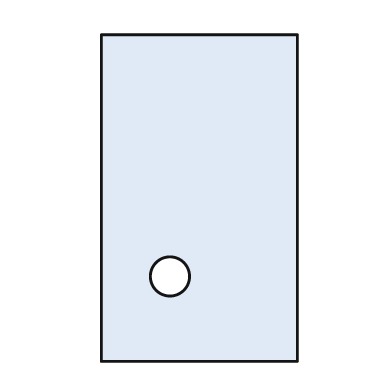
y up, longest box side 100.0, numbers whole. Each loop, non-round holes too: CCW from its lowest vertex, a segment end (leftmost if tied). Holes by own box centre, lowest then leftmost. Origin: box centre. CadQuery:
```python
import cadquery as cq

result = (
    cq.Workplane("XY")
    .moveTo(-30.0, -50.0)
    .lineTo(30.0, -50.0)
    .lineTo(30.0, 50.0)
    .lineTo(-30.0, 50.0)
    .close()
    .moveTo(-9.0, -24.0)
    .circle(6.0)
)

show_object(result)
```